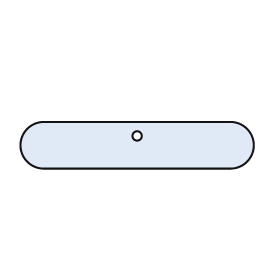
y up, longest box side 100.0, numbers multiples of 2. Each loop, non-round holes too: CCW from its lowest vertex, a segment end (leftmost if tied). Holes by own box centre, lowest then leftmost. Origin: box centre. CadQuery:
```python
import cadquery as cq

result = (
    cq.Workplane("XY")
    .moveTo(-40.0, -10.0)
    .lineTo(40.0, -10.0)
    .threePointArc((50.0, 0.0), (40.0, 10.0))
    .lineTo(-40.0, 10.0)
    .threePointArc((-50.0, 0.0), (-40.0, -10.0))
    .close()
    .moveTo(0.0, 4.0)
    .circle(2.0)
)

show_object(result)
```